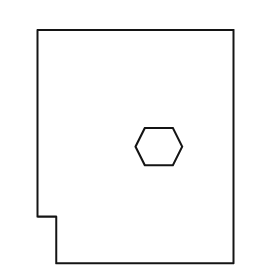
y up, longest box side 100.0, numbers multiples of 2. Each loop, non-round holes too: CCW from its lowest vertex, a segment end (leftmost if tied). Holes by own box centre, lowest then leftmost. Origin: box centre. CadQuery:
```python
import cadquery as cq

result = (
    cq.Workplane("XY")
    .moveTo(-34.0, -50.0)
    .lineTo(42.0, -50.0)
    .lineTo(42.0, 50.0)
    .lineTo(-42.0, 50.0)
    .lineTo(-42.0, -30.0)
    .lineTo(-34.0, -30.0)
    .close()
    .moveTo(4.0, -8.0)
    .lineTo(16.0, -8.0)
    .lineTo(20.0, 0.0)
    .lineTo(16.0, 8.0)
    .lineTo(4.0, 8.0)
    .lineTo(0.0, 0.0)
    .close()
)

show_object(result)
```